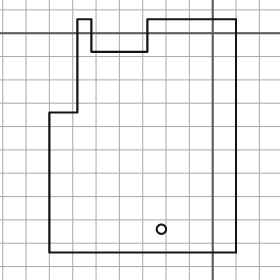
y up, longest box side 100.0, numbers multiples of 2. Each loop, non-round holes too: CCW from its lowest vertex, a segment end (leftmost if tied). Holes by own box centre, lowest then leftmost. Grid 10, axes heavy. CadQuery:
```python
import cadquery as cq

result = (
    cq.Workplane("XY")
    .moveTo(-70.0, -94.0)
    .lineTo(10.0, -94.0)
    .lineTo(10.0, 6.0)
    .lineTo(-28.0, 6.0)
    .lineTo(-28.0, -8.0)
    .lineTo(-52.0, -8.0)
    .lineTo(-52.0, 6.0)
    .lineTo(-58.0, 6.0)
    .lineTo(-58.0, -34.0)
    .lineTo(-70.0, -34.0)
    .close()
    .moveTo(-22.0, -84.0)
    .circle(2.0)
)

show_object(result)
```